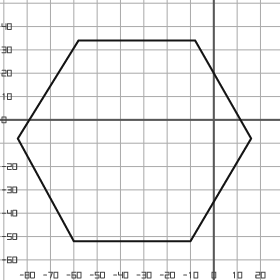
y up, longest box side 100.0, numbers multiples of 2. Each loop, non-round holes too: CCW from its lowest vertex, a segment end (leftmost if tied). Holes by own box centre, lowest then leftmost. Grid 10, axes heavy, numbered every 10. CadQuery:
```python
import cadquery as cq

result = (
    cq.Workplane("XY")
    .moveTo(-60.0, -52.0)
    .lineTo(-10.0, -52.0)
    .lineTo(16.0, -8.0)
    .lineTo(-8.0, 34.0)
    .lineTo(-58.0, 34.0)
    .lineTo(-84.0, -8.0)
    .close()
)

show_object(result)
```